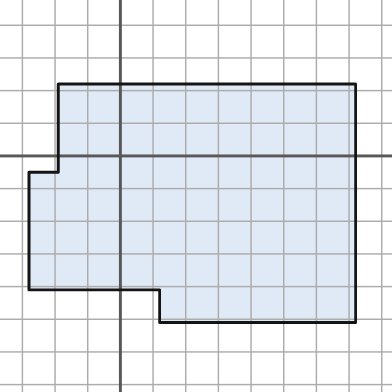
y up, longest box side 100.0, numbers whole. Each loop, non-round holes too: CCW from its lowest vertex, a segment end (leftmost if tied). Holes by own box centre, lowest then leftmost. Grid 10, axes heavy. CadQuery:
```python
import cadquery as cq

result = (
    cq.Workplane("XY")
    .moveTo(12.0, -51.0)
    .lineTo(72.0, -51.0)
    .lineTo(72.0, 22.0)
    .lineTo(-19.0, 22.0)
    .lineTo(-19.0, -5.0)
    .lineTo(-28.0, -5.0)
    .lineTo(-28.0, -41.0)
    .lineTo(12.0, -41.0)
    .close()
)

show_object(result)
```